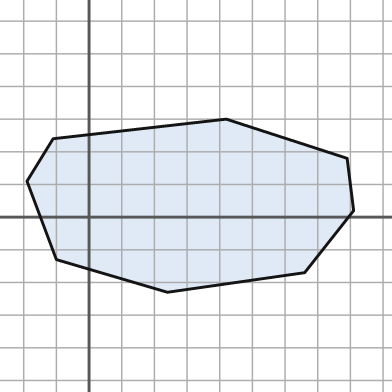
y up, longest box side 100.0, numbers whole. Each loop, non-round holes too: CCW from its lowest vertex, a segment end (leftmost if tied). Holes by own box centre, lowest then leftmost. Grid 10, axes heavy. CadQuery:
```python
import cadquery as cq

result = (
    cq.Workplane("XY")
    .moveTo(24.0, -23.0)
    .lineTo(66.0, -17.0)
    .lineTo(81.0, 2.0)
    .lineTo(79.0, 18.0)
    .lineTo(42.0, 30.0)
    .lineTo(-11.0, 24.0)
    .lineTo(-19.0, 11.0)
    .lineTo(-10.0, -13.0)
    .close()
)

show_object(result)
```